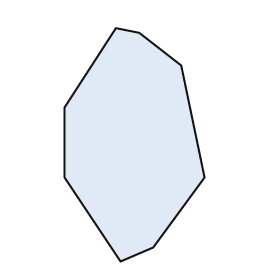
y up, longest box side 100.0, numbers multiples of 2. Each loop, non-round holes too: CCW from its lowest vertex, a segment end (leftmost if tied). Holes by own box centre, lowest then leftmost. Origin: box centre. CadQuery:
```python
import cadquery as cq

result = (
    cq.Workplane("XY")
    .moveTo(-6.0, -50.0)
    .lineTo(8.0, -44.0)
    .lineTo(30.0, -14.0)
    .lineTo(20.0, 34.0)
    .lineTo(2.0, 48.0)
    .lineTo(-8.0, 50.0)
    .lineTo(-30.0, 16.0)
    .lineTo(-30.0, -14.0)
    .close()
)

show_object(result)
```